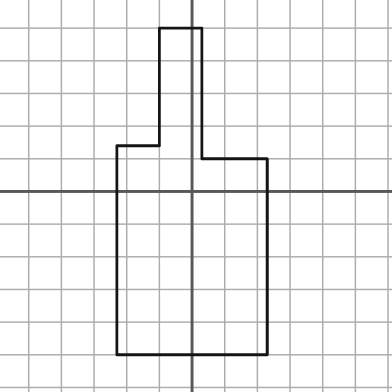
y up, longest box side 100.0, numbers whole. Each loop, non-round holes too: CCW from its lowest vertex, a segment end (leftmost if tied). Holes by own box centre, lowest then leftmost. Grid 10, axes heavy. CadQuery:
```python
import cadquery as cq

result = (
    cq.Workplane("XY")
    .moveTo(-23.0, -50.0)
    .lineTo(23.0, -50.0)
    .lineTo(23.0, 10.0)
    .lineTo(3.0, 10.0)
    .lineTo(3.0, 50.0)
    .lineTo(-10.0, 50.0)
    .lineTo(-10.0, 14.0)
    .lineTo(-23.0, 14.0)
    .close()
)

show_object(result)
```